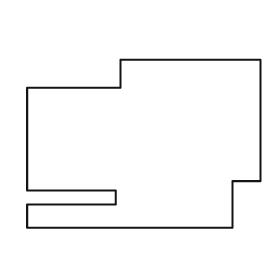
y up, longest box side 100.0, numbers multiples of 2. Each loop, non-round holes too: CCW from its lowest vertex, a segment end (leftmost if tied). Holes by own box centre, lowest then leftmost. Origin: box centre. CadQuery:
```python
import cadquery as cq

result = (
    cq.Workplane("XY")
    .moveTo(-50.0, -36.0)
    .lineTo(38.0, -36.0)
    .lineTo(38.0, -16.0)
    .lineTo(50.0, -16.0)
    .lineTo(50.0, 36.0)
    .lineTo(-10.0, 36.0)
    .lineTo(-10.0, 24.0)
    .lineTo(-50.0, 24.0)
    .lineTo(-50.0, -20.0)
    .lineTo(-12.0, -20.0)
    .lineTo(-12.0, -26.0)
    .lineTo(-50.0, -26.0)
    .close()
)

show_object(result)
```